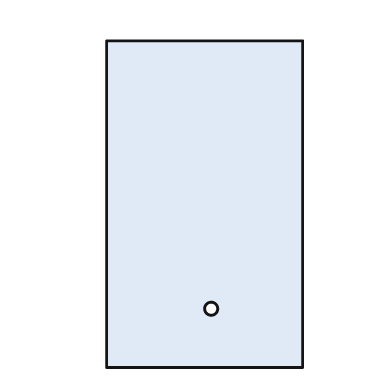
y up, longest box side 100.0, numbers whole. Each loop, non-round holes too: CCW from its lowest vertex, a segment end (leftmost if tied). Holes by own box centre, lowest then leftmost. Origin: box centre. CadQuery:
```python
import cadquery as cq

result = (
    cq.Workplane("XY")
    .moveTo(-30.0, -50.0)
    .lineTo(30.0, -50.0)
    .lineTo(30.0, 50.0)
    .lineTo(-30.0, 50.0)
    .close()
    .moveTo(2.0, -32.0)
    .circle(2.0)
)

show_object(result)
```